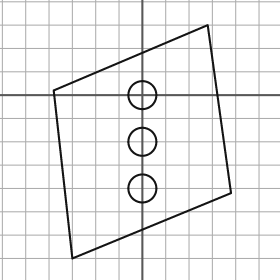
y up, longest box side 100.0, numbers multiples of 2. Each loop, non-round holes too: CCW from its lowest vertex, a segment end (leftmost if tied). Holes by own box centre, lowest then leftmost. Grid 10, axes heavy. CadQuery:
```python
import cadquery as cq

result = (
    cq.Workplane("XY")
    .moveTo(-30.0, -70.0)
    .lineTo(38.0, -42.0)
    .lineTo(28.0, 30.0)
    .lineTo(-38.0, 2.0)
    .close()
    .moveTo(0.0, -40.0)
    .circle(6.0)
    .moveTo(0.0, -20.0)
    .circle(6.0)
    .moveTo(0.0, 0.0)
    .circle(6.0)
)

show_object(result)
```